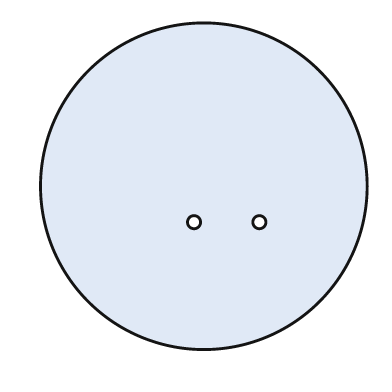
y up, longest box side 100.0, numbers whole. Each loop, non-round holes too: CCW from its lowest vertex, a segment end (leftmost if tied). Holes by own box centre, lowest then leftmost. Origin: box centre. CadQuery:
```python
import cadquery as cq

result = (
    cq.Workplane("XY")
    .moveTo(0.0, 0.0)
    .circle(50.0)
    .moveTo(-3.0, -11.0)
    .circle(2.0)
    .moveTo(17.0, -11.0)
    .circle(2.0)
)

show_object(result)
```